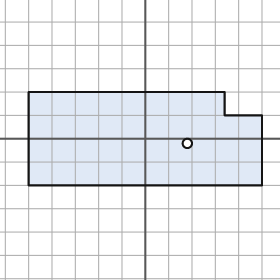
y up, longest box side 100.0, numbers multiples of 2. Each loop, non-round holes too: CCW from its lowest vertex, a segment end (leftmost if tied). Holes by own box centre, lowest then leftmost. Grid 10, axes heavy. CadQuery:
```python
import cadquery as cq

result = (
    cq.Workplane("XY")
    .moveTo(-50.0, -20.0)
    .lineTo(50.0, -20.0)
    .lineTo(50.0, 10.0)
    .lineTo(34.0, 10.0)
    .lineTo(34.0, 20.0)
    .lineTo(-50.0, 20.0)
    .close()
    .moveTo(18.0, -2.0)
    .circle(2.0)
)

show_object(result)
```